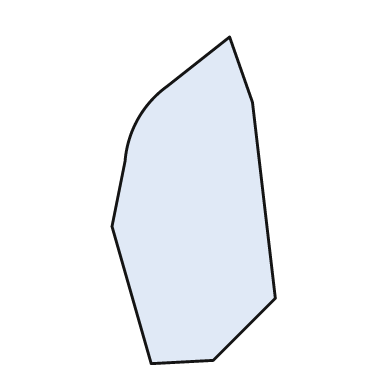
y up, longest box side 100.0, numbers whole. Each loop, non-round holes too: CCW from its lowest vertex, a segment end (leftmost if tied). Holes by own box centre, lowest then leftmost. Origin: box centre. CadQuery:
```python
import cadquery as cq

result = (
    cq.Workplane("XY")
    .moveTo(-13.0, -50.0)
    .lineTo(6.0, -49.0)
    .lineTo(25.0, -30.0)
    .lineTo(18.0, 30.0)
    .lineTo(11.0, 50.0)
    .lineTo(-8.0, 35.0)
    .threePointArc((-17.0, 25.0), (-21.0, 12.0))
    .lineTo(-25.0, -8.0)
    .close()
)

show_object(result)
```